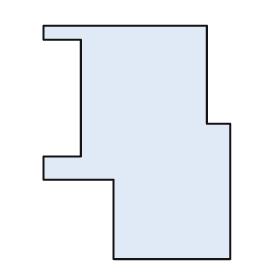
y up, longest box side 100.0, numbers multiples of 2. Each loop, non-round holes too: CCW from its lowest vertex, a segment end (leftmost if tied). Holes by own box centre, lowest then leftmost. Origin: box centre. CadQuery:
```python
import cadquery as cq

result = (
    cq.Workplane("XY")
    .moveTo(-10.0, -50.0)
    .lineTo(40.0, -50.0)
    .lineTo(40.0, 8.0)
    .lineTo(30.0, 8.0)
    .lineTo(30.0, 50.0)
    .lineTo(-40.0, 50.0)
    .lineTo(-40.0, 44.0)
    .lineTo(-24.0, 44.0)
    .lineTo(-24.0, -6.0)
    .lineTo(-40.0, -6.0)
    .lineTo(-40.0, -16.0)
    .lineTo(-10.0, -16.0)
    .close()
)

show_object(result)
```